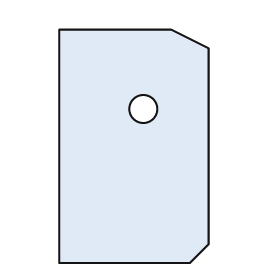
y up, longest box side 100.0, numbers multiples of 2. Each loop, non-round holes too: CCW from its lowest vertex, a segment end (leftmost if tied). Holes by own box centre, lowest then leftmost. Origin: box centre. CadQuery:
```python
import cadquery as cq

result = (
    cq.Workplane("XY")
    .moveTo(-32.0, -50.0)
    .lineTo(24.0, -50.0)
    .lineTo(32.0, -42.0)
    .lineTo(32.0, 42.0)
    .lineTo(16.0, 50.0)
    .lineTo(-32.0, 50.0)
    .close()
    .moveTo(4.0, 16.0)
    .circle(6.0)
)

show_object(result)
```